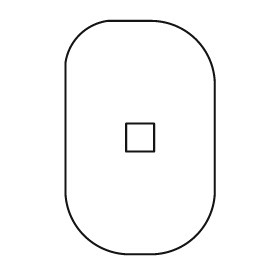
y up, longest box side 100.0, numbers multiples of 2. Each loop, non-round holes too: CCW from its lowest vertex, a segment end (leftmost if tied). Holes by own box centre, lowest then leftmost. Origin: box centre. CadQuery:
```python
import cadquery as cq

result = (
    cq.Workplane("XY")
    .moveTo(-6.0, -50.0)
    .lineTo(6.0, -50.0)
    .threePointArc((24.0, -42.0), (32.0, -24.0))
    .lineTo(32.0, 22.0)
    .threePointArc((24.0, 42.0), (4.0, 50.0))
    .lineTo(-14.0, 50.0)
    .threePointArc((-26.0, 44.0), (-32.0, 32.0))
    .lineTo(-32.0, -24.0)
    .threePointArc((-24.0, -42.0), (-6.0, -50.0))
    .close()
    .moveTo(-6.0, -6.0)
    .lineTo(6.0, -6.0)
    .lineTo(6.0, 6.0)
    .lineTo(-6.0, 6.0)
    .close()
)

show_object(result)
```